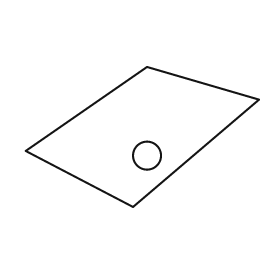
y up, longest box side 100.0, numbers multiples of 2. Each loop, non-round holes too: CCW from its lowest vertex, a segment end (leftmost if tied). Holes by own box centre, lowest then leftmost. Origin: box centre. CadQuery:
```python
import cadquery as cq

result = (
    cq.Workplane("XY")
    .moveTo(-4.0, -30.0)
    .lineTo(50.0, 16.0)
    .lineTo(2.0, 30.0)
    .lineTo(-50.0, -6.0)
    .close()
    .moveTo(2.0, -8.0)
    .circle(6.0)
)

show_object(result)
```